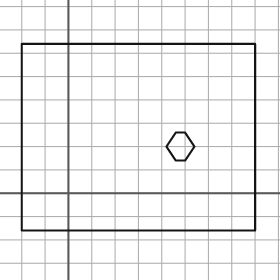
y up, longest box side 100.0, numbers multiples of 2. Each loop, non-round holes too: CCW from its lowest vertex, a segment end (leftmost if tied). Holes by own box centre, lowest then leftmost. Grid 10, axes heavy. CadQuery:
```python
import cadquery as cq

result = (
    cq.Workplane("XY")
    .moveTo(-20.0, -16.0)
    .lineTo(80.0, -16.0)
    .lineTo(80.0, 64.0)
    .lineTo(-20.0, 64.0)
    .close()
    .moveTo(46.0, 14.0)
    .lineTo(50.0, 14.0)
    .lineTo(54.0, 20.0)
    .lineTo(50.0, 26.0)
    .lineTo(46.0, 26.0)
    .lineTo(42.0, 20.0)
    .close()
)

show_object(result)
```